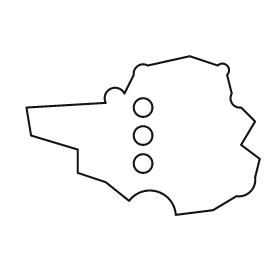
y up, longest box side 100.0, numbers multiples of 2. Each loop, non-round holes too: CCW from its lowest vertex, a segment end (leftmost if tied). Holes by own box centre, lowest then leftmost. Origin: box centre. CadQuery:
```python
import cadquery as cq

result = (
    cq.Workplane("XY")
    .moveTo(14.0, -34.0)
    .lineTo(30.0, -32.0)
    .lineTo(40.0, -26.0)
    .threePointArc((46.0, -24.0), (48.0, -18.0))
    .lineTo(50.0, -10.0)
    .lineTo(42.0, -4.0)
    .lineTo(48.0, 6.0)
    .lineTo(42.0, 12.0)
    .threePointArc((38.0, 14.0), (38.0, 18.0))
    .lineTo(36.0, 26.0)
    .threePointArc((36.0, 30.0), (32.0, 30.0))
    .lineTo(20.0, 34.0)
    .lineTo(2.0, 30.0)
    .threePointArc((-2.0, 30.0), (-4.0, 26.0))
    .lineTo(-8.0, 18.0)
    .threePointArc((-14.0, 20.0), (-16.0, 14.0))
    .lineTo(-50.0, 12.0)
    .lineTo(-48.0, 0.0)
    .lineTo(-28.0, -6.0)
    .lineTo(-28.0, -16.0)
    .lineTo(-16.0, -20.0)
    .lineTo(-6.0, -28.0)
    .threePointArc((6.0, -24.0), (14.0, -34.0))
    .close()
    .moveTo(0.0, -12.0)
    .circle(4.0)
    .moveTo(0.0, 0.0)
    .circle(4.0)
    .moveTo(0.0, 12.0)
    .circle(4.0)
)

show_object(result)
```